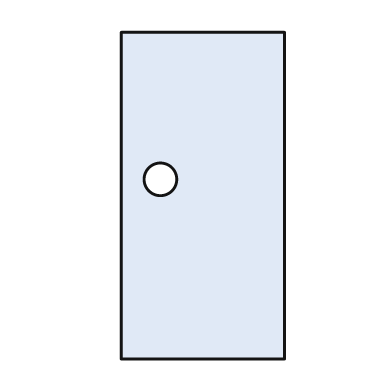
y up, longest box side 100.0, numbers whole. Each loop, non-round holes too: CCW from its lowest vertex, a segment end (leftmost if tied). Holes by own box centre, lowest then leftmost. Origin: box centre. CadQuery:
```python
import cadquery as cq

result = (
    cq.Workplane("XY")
    .moveTo(-25.0, -50.0)
    .lineTo(25.0, -50.0)
    .lineTo(25.0, 50.0)
    .lineTo(-25.0, 50.0)
    .close()
    .moveTo(-13.0, 5.0)
    .circle(5.0)
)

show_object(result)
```